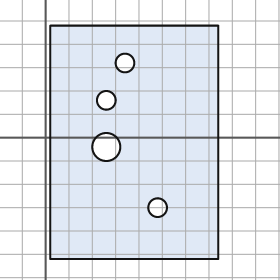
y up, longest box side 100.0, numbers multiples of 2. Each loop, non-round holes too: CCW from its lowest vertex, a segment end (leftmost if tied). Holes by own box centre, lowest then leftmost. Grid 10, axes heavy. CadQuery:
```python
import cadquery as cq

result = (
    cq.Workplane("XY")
    .moveTo(2.0, -52.0)
    .lineTo(74.0, -52.0)
    .lineTo(74.0, 48.0)
    .lineTo(2.0, 48.0)
    .close()
    .moveTo(48.0, -30.0)
    .circle(4.0)
    .moveTo(26.0, -4.0)
    .circle(6.0)
    .moveTo(26.0, 16.0)
    .circle(4.0)
    .moveTo(34.0, 32.0)
    .circle(4.0)
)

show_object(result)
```